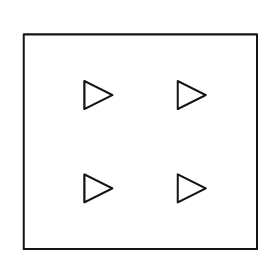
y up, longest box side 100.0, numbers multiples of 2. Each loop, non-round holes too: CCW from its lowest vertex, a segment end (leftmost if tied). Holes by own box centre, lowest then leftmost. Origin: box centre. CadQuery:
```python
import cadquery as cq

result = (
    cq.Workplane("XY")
    .moveTo(-50.0, -46.0)
    .lineTo(50.0, -46.0)
    .lineTo(50.0, 46.0)
    .lineTo(-50.0, 46.0)
    .close()
    .moveTo(-24.0, -26.0)
    .lineTo(-12.0, -20.0)
    .lineTo(-24.0, -14.0)
    .close()
    .moveTo(16.0, -26.0)
    .lineTo(28.0, -20.0)
    .lineTo(16.0, -14.0)
    .close()
    .moveTo(-24.0, 14.0)
    .lineTo(-12.0, 20.0)
    .lineTo(-24.0, 26.0)
    .close()
    .moveTo(16.0, 14.0)
    .lineTo(28.0, 20.0)
    .lineTo(16.0, 26.0)
    .close()
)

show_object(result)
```